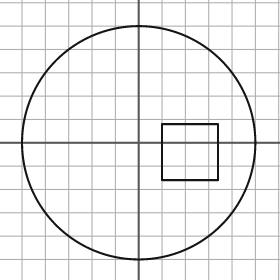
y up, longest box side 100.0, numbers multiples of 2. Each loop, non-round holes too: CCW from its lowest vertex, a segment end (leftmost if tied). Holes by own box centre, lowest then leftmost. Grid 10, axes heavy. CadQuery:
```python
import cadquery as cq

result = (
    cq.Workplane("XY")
    .moveTo(0.0, 0.0)
    .circle(50.0)
    .moveTo(10.0, -16.0)
    .lineTo(34.0, -16.0)
    .lineTo(34.0, 8.0)
    .lineTo(10.0, 8.0)
    .close()
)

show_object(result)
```